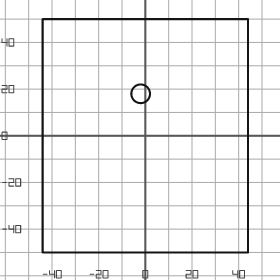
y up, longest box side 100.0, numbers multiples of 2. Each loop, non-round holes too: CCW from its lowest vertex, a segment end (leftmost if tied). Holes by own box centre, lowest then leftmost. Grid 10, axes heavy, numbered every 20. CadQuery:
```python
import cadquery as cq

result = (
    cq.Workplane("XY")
    .moveTo(-44.0, -50.0)
    .lineTo(44.0, -50.0)
    .lineTo(44.0, 50.0)
    .lineTo(-44.0, 50.0)
    .close()
    .moveTo(-2.0, 18.0)
    .circle(4.0)
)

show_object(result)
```